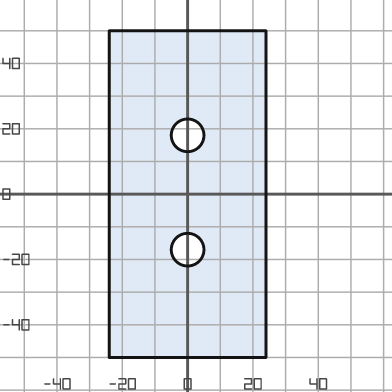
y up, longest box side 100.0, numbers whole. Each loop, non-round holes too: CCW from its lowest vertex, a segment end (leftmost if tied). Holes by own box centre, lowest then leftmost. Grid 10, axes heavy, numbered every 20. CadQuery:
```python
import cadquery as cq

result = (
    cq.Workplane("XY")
    .moveTo(-24.0, -50.0)
    .lineTo(24.0, -50.0)
    .lineTo(24.0, 50.0)
    .lineTo(-24.0, 50.0)
    .close()
    .moveTo(0.0, -17.0)
    .circle(5.0)
    .moveTo(0.0, 18.0)
    .circle(5.0)
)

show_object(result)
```